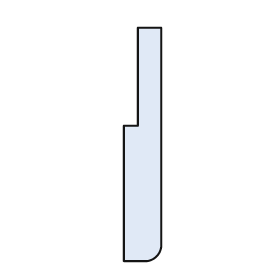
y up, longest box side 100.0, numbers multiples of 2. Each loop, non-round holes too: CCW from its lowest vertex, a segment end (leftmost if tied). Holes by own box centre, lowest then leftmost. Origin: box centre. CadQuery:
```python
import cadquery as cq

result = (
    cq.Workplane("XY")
    .moveTo(-8.0, -50.0)
    .lineTo(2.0, -50.0)
    .threePointArc((6.0, -48.0), (8.0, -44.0))
    .lineTo(8.0, 50.0)
    .lineTo(-2.0, 50.0)
    .lineTo(-2.0, 8.0)
    .lineTo(-8.0, 8.0)
    .close()
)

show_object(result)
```